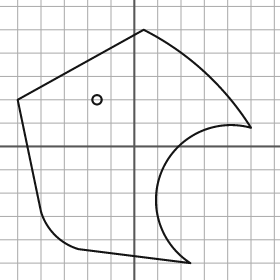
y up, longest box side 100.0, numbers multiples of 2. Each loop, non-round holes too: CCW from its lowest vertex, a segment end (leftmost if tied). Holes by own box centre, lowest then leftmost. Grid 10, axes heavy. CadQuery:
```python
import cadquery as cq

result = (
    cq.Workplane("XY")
    .moveTo(24.0, -50.0)
    .threePointArc((12.0, -10.0), (50.0, 8.0))
    .threePointArc((30.0, 32.0), (4.0, 50.0))
    .lineTo(-50.0, 20.0)
    .lineTo(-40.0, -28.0)
    .threePointArc((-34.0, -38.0), (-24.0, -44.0))
    .close()
    .moveTo(-16.0, 20.0)
    .circle(2.0)
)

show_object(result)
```